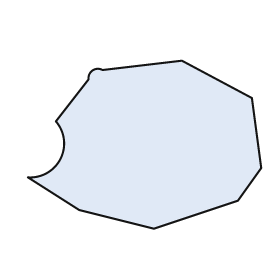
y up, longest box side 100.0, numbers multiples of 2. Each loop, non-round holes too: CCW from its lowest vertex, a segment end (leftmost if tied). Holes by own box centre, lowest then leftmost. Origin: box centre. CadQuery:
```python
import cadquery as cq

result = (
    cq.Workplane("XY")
    .moveTo(4.0, -36.0)
    .lineTo(40.0, -24.0)
    .lineTo(50.0, -10.0)
    .lineTo(46.0, 20.0)
    .lineTo(16.0, 36.0)
    .lineTo(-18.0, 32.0)
    .threePointArc((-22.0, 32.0), (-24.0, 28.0))
    .lineTo(-38.0, 10.0)
    .threePointArc((-36.0, -6.0), (-50.0, -14.0))
    .lineTo(-28.0, -28.0)
    .close()
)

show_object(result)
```